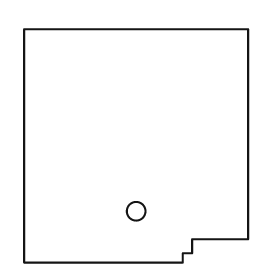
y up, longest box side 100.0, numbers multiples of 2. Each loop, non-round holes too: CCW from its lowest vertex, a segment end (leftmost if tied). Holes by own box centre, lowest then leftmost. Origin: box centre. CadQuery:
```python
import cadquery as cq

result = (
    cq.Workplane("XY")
    .moveTo(-48.0, -50.0)
    .lineTo(20.0, -50.0)
    .lineTo(20.0, -46.0)
    .lineTo(24.0, -46.0)
    .lineTo(24.0, -40.0)
    .lineTo(48.0, -40.0)
    .lineTo(48.0, 50.0)
    .lineTo(-48.0, 50.0)
    .close()
    .moveTo(0.0, -28.0)
    .circle(4.0)
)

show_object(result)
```